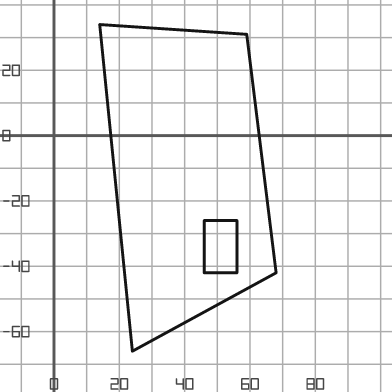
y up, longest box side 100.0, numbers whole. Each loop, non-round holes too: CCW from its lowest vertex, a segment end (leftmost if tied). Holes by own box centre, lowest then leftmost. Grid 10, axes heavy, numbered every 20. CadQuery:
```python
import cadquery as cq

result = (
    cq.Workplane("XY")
    .moveTo(24.0, -66.0)
    .lineTo(68.0, -42.0)
    .lineTo(59.0, 31.0)
    .lineTo(14.0, 34.0)
    .close()
    .moveTo(46.0, -42.0)
    .lineTo(56.0, -42.0)
    .lineTo(56.0, -26.0)
    .lineTo(46.0, -26.0)
    .close()
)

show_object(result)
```